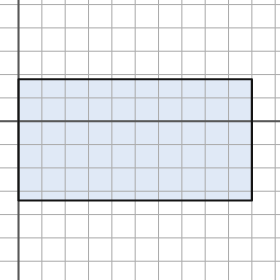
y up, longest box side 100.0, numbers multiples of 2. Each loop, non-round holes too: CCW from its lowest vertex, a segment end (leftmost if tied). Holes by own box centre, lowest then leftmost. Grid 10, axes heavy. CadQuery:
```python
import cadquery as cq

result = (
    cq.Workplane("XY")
    .moveTo(0.0, -34.0)
    .lineTo(100.0, -34.0)
    .lineTo(100.0, 18.0)
    .lineTo(0.0, 18.0)
    .close()
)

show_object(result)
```